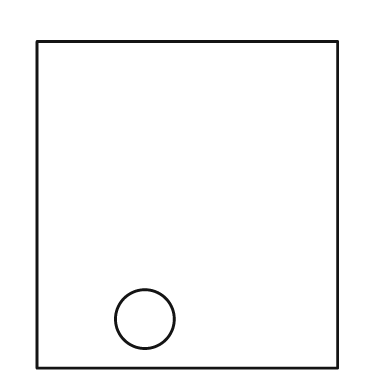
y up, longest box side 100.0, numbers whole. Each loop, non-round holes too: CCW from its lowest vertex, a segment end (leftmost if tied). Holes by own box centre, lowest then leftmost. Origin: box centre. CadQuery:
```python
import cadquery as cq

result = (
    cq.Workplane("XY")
    .moveTo(-46.0, -50.0)
    .lineTo(46.0, -50.0)
    .lineTo(46.0, 50.0)
    .lineTo(-46.0, 50.0)
    .close()
    .moveTo(-13.0, -35.0)
    .circle(9.0)
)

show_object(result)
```